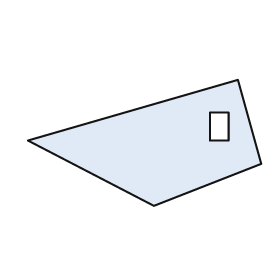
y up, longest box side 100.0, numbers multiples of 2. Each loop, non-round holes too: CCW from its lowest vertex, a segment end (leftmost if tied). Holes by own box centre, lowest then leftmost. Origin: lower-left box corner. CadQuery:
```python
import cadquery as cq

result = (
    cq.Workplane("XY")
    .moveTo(54.0, 0.0)
    .lineTo(100.0, 18.0)
    .lineTo(90.0, 54.0)
    .lineTo(0.0, 28.0)
    .close()
    .moveTo(78.0, 28.0)
    .lineTo(86.0, 28.0)
    .lineTo(86.0, 40.0)
    .lineTo(78.0, 40.0)
    .close()
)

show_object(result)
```